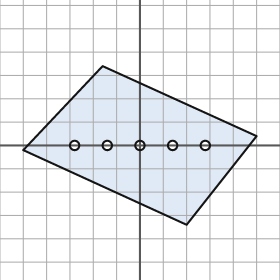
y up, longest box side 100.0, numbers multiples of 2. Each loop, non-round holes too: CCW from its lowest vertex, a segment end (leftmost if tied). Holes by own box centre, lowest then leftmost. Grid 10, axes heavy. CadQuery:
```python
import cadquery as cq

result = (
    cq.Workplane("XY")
    .moveTo(20.0, -34.0)
    .lineTo(50.0, 4.0)
    .lineTo(-16.0, 34.0)
    .lineTo(-50.0, -2.0)
    .close()
    .moveTo(-28.0, 0.0)
    .circle(2.0)
    .moveTo(-14.0, 0.0)
    .circle(2.0)
    .moveTo(0.0, 0.0)
    .circle(2.0)
    .moveTo(14.0, 0.0)
    .circle(2.0)
    .moveTo(28.0, 0.0)
    .circle(2.0)
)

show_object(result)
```